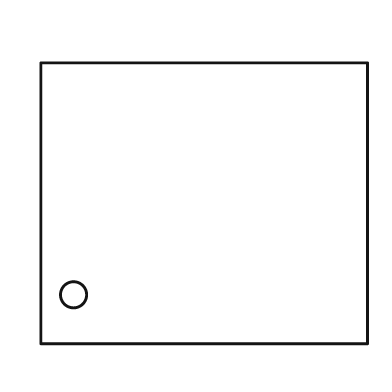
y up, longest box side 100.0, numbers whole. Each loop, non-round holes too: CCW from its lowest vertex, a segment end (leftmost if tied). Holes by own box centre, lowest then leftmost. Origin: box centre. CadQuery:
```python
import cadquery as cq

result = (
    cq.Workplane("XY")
    .moveTo(-50.0, -43.0)
    .lineTo(50.0, -43.0)
    .lineTo(50.0, 43.0)
    .lineTo(-50.0, 43.0)
    .close()
    .moveTo(-40.0, -28.0)
    .circle(4.0)
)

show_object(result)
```